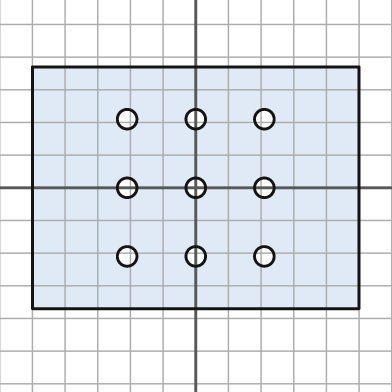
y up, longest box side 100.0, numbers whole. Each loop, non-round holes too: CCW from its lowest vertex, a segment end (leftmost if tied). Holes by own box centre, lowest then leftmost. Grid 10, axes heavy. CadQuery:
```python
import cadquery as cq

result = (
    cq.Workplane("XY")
    .moveTo(-50.0, -37.0)
    .lineTo(50.0, -37.0)
    .lineTo(50.0, 37.0)
    .lineTo(-50.0, 37.0)
    .close()
    .moveTo(-21.0, -21.0)
    .circle(3.0)
    .moveTo(0.0, -21.0)
    .circle(3.0)
    .moveTo(21.0, -21.0)
    .circle(3.0)
    .moveTo(-21.0, 0.0)
    .circle(3.0)
    .moveTo(0.0, 0.0)
    .circle(3.0)
    .moveTo(21.0, 0.0)
    .circle(3.0)
    .moveTo(-21.0, 21.0)
    .circle(3.0)
    .moveTo(0.0, 21.0)
    .circle(3.0)
    .moveTo(21.0, 21.0)
    .circle(3.0)
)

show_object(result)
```